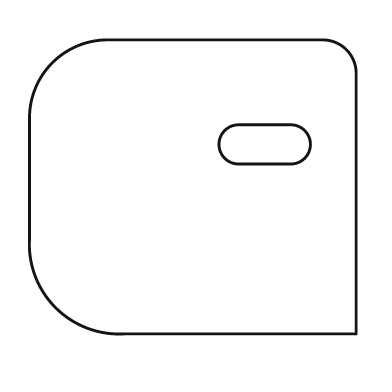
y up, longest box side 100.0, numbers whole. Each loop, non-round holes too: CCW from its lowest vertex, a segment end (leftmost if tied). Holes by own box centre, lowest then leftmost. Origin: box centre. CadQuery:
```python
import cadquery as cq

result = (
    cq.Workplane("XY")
    .moveTo(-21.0, -45.0)
    .lineTo(50.0, -45.0)
    .lineTo(50.0, 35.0)
    .threePointArc((47.0, 42.0), (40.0, 45.0))
    .lineTo(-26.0, 45.0)
    .threePointArc((-43.0, 38.0), (-50.0, 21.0))
    .lineTo(-50.0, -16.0)
    .threePointArc((-42.0, -37.0), (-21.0, -45.0))
    .close()
    .moveTo(14.0, 7.0)
    .lineTo(30.0, 7.0)
    .threePointArc((36.0, 13.0), (30.0, 19.0))
    .lineTo(14.0, 19.0)
    .threePointArc((8.0, 13.0), (14.0, 7.0))
    .close()
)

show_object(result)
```